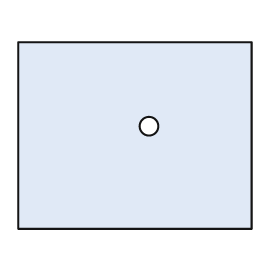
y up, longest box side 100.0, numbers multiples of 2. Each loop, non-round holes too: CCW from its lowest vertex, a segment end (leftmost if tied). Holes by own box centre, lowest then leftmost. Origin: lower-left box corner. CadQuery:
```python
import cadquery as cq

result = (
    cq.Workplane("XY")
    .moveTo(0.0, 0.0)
    .lineTo(100.0, 0.0)
    .lineTo(100.0, 80.0)
    .lineTo(0.0, 80.0)
    .close()
    .moveTo(56.0, 44.0)
    .circle(4.0)
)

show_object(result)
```